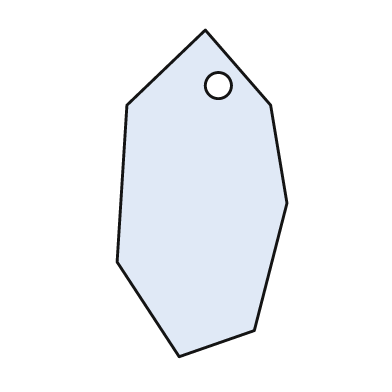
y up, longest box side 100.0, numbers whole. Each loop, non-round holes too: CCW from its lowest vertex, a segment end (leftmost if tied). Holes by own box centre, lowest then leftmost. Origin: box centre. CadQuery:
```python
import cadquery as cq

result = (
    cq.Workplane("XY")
    .moveTo(-7.0, -50.0)
    .lineTo(16.0, -42.0)
    .lineTo(26.0, -3.0)
    .lineTo(21.0, 27.0)
    .lineTo(1.0, 50.0)
    .lineTo(-23.0, 27.0)
    .lineTo(-26.0, -21.0)
    .close()
    .moveTo(5.0, 33.0)
    .circle(4.0)
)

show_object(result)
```